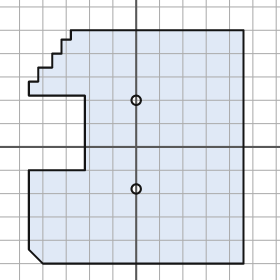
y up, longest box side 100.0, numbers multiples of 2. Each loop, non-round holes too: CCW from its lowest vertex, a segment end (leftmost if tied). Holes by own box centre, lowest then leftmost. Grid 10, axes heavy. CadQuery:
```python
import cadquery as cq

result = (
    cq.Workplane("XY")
    .moveTo(-40.0, -50.0)
    .lineTo(46.0, -50.0)
    .lineTo(46.0, 50.0)
    .lineTo(-28.0, 50.0)
    .lineTo(-28.0, 46.0)
    .lineTo(-32.0, 46.0)
    .lineTo(-32.0, 40.0)
    .lineTo(-36.0, 40.0)
    .lineTo(-36.0, 34.0)
    .lineTo(-42.0, 34.0)
    .lineTo(-42.0, 28.0)
    .lineTo(-46.0, 28.0)
    .lineTo(-46.0, 22.0)
    .lineTo(-22.0, 22.0)
    .lineTo(-22.0, -10.0)
    .lineTo(-46.0, -10.0)
    .lineTo(-46.0, -44.0)
    .close()
    .moveTo(0.0, -18.0)
    .circle(2.0)
    .moveTo(0.0, 20.0)
    .circle(2.0)
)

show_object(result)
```